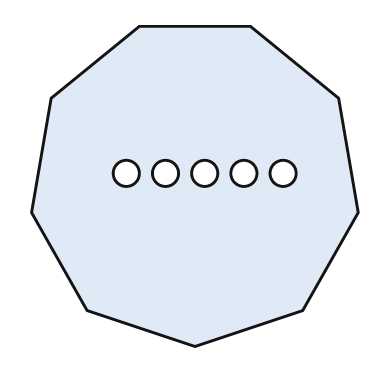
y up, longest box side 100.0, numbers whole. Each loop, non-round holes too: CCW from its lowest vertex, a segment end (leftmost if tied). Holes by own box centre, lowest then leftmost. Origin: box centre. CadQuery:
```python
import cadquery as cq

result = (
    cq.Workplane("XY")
    .moveTo(0.0, -49.0)
    .lineTo(33.0, -38.0)
    .lineTo(50.0, -8.0)
    .lineTo(44.0, 27.0)
    .lineTo(17.0, 49.0)
    .lineTo(-17.0, 49.0)
    .lineTo(-44.0, 27.0)
    .lineTo(-50.0, -8.0)
    .lineTo(-33.0, -38.0)
    .close()
    .moveTo(-21.0, 4.0)
    .circle(4.0)
    .moveTo(-9.0, 4.0)
    .circle(4.0)
    .moveTo(3.0, 4.0)
    .circle(4.0)
    .moveTo(15.0, 4.0)
    .circle(4.0)
    .moveTo(27.0, 4.0)
    .circle(4.0)
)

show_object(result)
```